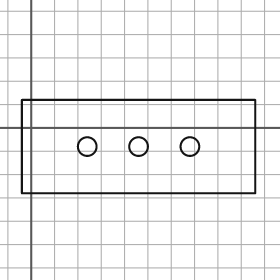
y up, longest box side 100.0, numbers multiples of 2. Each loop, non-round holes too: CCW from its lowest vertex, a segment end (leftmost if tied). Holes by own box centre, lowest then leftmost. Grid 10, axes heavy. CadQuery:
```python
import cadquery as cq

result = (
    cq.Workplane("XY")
    .moveTo(-4.0, -28.0)
    .lineTo(96.0, -28.0)
    .lineTo(96.0, 12.0)
    .lineTo(-4.0, 12.0)
    .close()
    .moveTo(24.0, -8.0)
    .circle(4.0)
    .moveTo(46.0, -8.0)
    .circle(4.0)
    .moveTo(68.0, -8.0)
    .circle(4.0)
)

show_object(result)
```